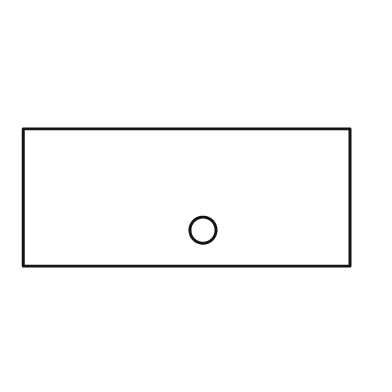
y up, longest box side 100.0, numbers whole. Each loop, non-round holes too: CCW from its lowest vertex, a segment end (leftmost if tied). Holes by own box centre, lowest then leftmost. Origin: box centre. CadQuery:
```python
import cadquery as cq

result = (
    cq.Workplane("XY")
    .moveTo(-50.0, -21.0)
    .lineTo(50.0, -21.0)
    .lineTo(50.0, 21.0)
    .lineTo(-50.0, 21.0)
    .close()
    .moveTo(5.0, -10.0)
    .circle(4.0)
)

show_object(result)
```